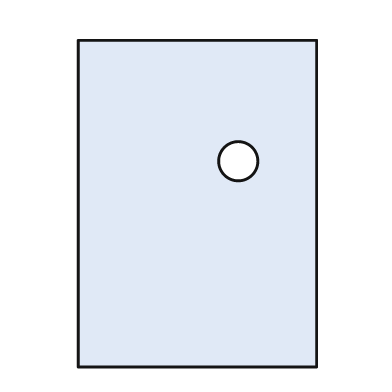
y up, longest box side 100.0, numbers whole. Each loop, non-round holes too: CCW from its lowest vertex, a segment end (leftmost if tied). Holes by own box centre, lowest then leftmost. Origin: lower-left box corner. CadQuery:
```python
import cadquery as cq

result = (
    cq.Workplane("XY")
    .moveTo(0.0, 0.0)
    .lineTo(73.0, 0.0)
    .lineTo(73.0, 100.0)
    .lineTo(0.0, 100.0)
    .close()
    .moveTo(49.0, 63.0)
    .circle(6.0)
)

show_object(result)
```